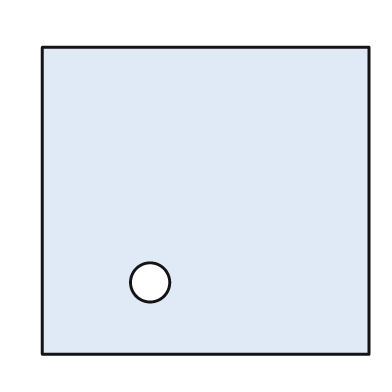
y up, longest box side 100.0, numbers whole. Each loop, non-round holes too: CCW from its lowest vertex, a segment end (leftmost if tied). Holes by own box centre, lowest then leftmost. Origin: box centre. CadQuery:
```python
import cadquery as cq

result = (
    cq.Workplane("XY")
    .moveTo(-50.0, -47.0)
    .lineTo(50.0, -47.0)
    .lineTo(50.0, 47.0)
    .lineTo(-50.0, 47.0)
    .close()
    .moveTo(-17.0, -25.0)
    .circle(6.0)
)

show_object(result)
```